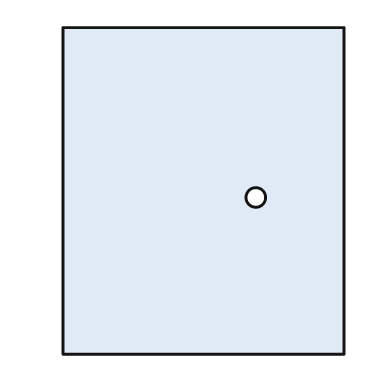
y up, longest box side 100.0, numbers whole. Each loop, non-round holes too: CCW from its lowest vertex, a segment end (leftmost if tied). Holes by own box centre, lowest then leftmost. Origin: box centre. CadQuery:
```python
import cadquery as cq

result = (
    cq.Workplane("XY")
    .moveTo(-43.0, -50.0)
    .lineTo(43.0, -50.0)
    .lineTo(43.0, 50.0)
    .lineTo(-43.0, 50.0)
    .close()
    .moveTo(16.0, -2.0)
    .circle(3.0)
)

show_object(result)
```